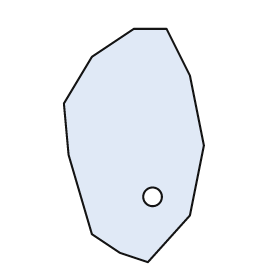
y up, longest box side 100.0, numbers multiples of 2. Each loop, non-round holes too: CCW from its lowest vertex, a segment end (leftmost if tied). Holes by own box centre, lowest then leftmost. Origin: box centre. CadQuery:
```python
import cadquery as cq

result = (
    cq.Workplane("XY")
    .moveTo(6.0, -50.0)
    .lineTo(24.0, -30.0)
    .lineTo(30.0, 0.0)
    .lineTo(24.0, 30.0)
    .lineTo(14.0, 50.0)
    .lineTo(0.0, 50.0)
    .lineTo(-18.0, 38.0)
    .lineTo(-30.0, 18.0)
    .lineTo(-28.0, -4.0)
    .lineTo(-18.0, -38.0)
    .lineTo(-6.0, -46.0)
    .close()
    .moveTo(8.0, -22.0)
    .circle(4.0)
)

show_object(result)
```